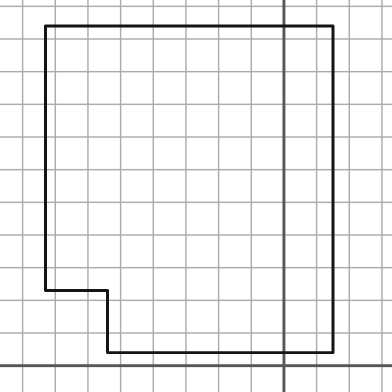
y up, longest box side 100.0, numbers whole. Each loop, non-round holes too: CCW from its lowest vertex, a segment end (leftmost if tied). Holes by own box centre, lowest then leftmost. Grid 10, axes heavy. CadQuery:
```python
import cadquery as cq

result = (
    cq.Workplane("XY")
    .moveTo(-54.0, 4.0)
    .lineTo(15.0, 4.0)
    .lineTo(15.0, 104.0)
    .lineTo(-73.0, 104.0)
    .lineTo(-73.0, 23.0)
    .lineTo(-54.0, 23.0)
    .close()
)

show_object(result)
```